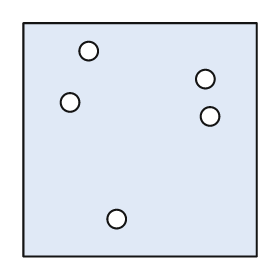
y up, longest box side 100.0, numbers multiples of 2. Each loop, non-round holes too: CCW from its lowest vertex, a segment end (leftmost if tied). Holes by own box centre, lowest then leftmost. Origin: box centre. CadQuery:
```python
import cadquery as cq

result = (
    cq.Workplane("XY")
    .moveTo(-50.0, -50.0)
    .lineTo(50.0, -50.0)
    .lineTo(50.0, 50.0)
    .lineTo(-50.0, 50.0)
    .close()
    .moveTo(-10.0, -34.0)
    .circle(4.0)
    .moveTo(30.0, 10.0)
    .circle(4.0)
    .moveTo(-30.0, 16.0)
    .circle(4.0)
    .moveTo(28.0, 26.0)
    .circle(4.0)
    .moveTo(-22.0, 38.0)
    .circle(4.0)
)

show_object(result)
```